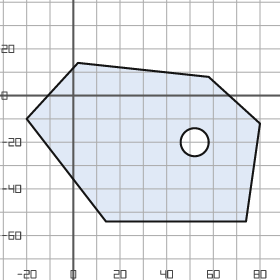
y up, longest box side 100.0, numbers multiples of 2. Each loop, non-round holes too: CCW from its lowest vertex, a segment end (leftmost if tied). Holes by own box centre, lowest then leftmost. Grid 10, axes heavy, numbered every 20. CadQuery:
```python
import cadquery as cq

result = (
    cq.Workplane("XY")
    .moveTo(14.0, -54.0)
    .lineTo(74.0, -54.0)
    .lineTo(80.0, -12.0)
    .lineTo(58.0, 8.0)
    .lineTo(2.0, 14.0)
    .lineTo(-20.0, -10.0)
    .close()
    .moveTo(52.0, -20.0)
    .circle(6.0)
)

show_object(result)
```